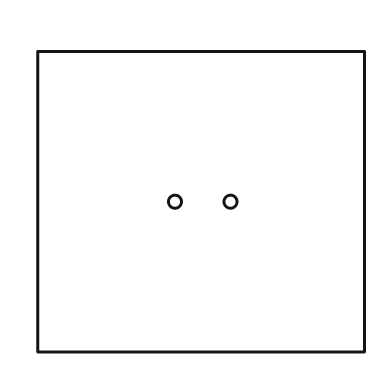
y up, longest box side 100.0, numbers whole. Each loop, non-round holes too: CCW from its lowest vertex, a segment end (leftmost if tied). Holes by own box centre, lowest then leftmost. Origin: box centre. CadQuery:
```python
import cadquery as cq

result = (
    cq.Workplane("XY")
    .moveTo(-50.0, -46.0)
    .lineTo(50.0, -46.0)
    .lineTo(50.0, 46.0)
    .lineTo(-50.0, 46.0)
    .close()
    .moveTo(-8.0, 0.0)
    .circle(2.0)
    .moveTo(9.0, 0.0)
    .circle(2.0)
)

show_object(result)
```